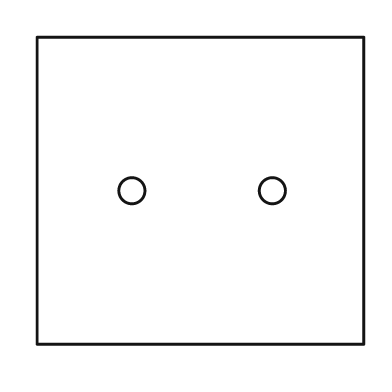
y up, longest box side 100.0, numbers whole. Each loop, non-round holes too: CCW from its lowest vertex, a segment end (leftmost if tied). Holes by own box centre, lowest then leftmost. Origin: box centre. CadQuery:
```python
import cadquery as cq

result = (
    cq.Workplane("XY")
    .moveTo(-50.0, -47.0)
    .lineTo(50.0, -47.0)
    .lineTo(50.0, 47.0)
    .lineTo(-50.0, 47.0)
    .close()
    .moveTo(-21.0, 0.0)
    .circle(4.0)
    .moveTo(22.0, 0.0)
    .circle(4.0)
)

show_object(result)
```